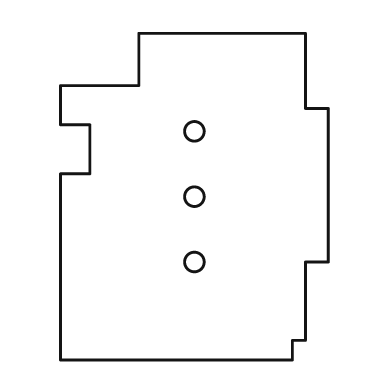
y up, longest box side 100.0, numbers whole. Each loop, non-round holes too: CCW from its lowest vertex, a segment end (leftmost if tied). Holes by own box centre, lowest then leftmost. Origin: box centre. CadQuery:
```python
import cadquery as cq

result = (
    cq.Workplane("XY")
    .moveTo(-41.0, -50.0)
    .lineTo(30.0, -50.0)
    .lineTo(30.0, -44.0)
    .lineTo(34.0, -44.0)
    .lineTo(34.0, -20.0)
    .lineTo(41.0, -20.0)
    .lineTo(41.0, 27.0)
    .lineTo(34.0, 27.0)
    .lineTo(34.0, 50.0)
    .lineTo(-17.0, 50.0)
    .lineTo(-17.0, 34.0)
    .lineTo(-41.0, 34.0)
    .lineTo(-41.0, 22.0)
    .lineTo(-32.0, 22.0)
    .lineTo(-32.0, 7.0)
    .lineTo(-41.0, 7.0)
    .close()
    .moveTo(0.0, -20.0)
    .circle(3.0)
    .moveTo(0.0, 0.0)
    .circle(3.0)
    .moveTo(0.0, 20.0)
    .circle(3.0)
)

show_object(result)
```